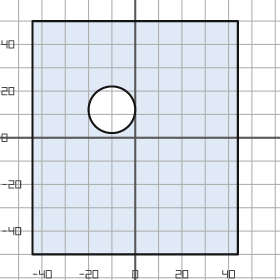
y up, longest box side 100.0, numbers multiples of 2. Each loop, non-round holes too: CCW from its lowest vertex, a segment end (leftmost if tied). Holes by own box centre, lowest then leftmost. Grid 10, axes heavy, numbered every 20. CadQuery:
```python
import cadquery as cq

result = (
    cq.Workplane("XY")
    .moveTo(-44.0, -50.0)
    .lineTo(44.0, -50.0)
    .lineTo(44.0, 50.0)
    .lineTo(-44.0, 50.0)
    .close()
    .moveTo(-10.0, 12.0)
    .circle(10.0)
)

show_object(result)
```